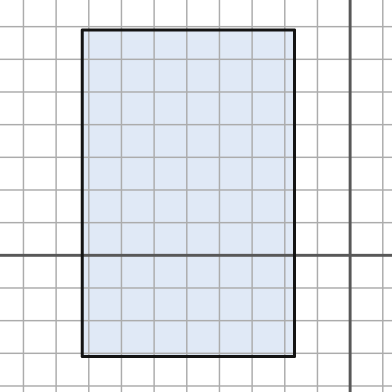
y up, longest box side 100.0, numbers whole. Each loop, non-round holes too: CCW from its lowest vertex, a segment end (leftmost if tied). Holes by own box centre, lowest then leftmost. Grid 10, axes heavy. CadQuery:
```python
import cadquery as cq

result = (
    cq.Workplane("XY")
    .moveTo(-82.0, -31.0)
    .lineTo(-17.0, -31.0)
    .lineTo(-17.0, 69.0)
    .lineTo(-82.0, 69.0)
    .close()
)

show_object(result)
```